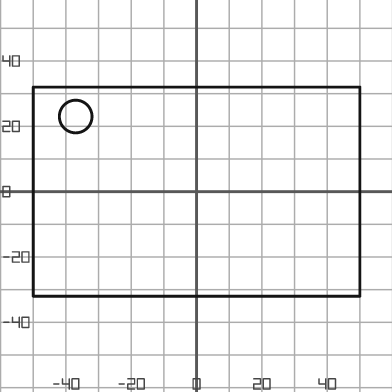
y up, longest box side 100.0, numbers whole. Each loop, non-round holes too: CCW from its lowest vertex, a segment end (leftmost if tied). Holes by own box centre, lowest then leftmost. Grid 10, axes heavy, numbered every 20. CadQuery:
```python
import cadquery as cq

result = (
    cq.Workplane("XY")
    .moveTo(-50.0, -32.0)
    .lineTo(50.0, -32.0)
    .lineTo(50.0, 32.0)
    .lineTo(-50.0, 32.0)
    .close()
    .moveTo(-37.0, 23.0)
    .circle(5.0)
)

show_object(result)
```